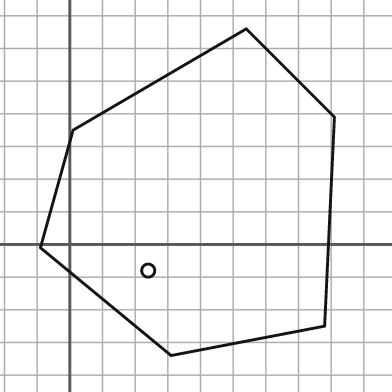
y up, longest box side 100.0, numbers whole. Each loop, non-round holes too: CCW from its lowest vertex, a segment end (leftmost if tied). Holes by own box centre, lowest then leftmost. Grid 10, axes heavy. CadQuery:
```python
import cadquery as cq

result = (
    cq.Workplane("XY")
    .moveTo(31.0, -34.0)
    .lineTo(78.0, -25.0)
    .lineTo(81.0, 39.0)
    .lineTo(54.0, 66.0)
    .lineTo(1.0, 35.0)
    .lineTo(-9.0, -1.0)
    .close()
    .moveTo(24.0, -8.0)
    .circle(2.0)
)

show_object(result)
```